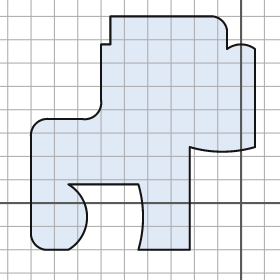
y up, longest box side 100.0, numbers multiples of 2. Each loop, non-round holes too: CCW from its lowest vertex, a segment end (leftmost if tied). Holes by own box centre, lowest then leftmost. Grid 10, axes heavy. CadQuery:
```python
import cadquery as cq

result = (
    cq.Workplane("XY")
    .moveTo(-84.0, -20.0)
    .lineTo(-74.0, -20.0)
    .threePointArc((-66.0, -6.0), (-74.0, 8.0))
    .lineTo(-44.0, 8.0)
    .threePointArc((-42.0, -6.0), (-44.0, -20.0))
    .lineTo(-22.0, -20.0)
    .lineTo(-22.0, 24.0)
    .threePointArc((-8.0, 22.0), (6.0, 24.0))
    .lineTo(6.0, 66.0)
    .threePointArc((0.0, 68.0), (-6.0, 66.0))
    .lineTo(-6.0, 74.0)
    .threePointArc((-8.0, 78.0), (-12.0, 80.0))
    .lineTo(-56.0, 80.0)
    .lineTo(-56.0, 68.0)
    .lineTo(-60.0, 68.0)
    .lineTo(-60.0, 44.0)
    .threePointArc((-62.0, 38.0), (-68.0, 36.0))
    .lineTo(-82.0, 36.0)
    .threePointArc((-88.0, 34.0), (-90.0, 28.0))
    .lineTo(-90.0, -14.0)
    .threePointArc((-88.0, -18.0), (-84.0, -20.0))
    .close()
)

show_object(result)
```